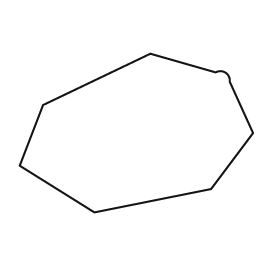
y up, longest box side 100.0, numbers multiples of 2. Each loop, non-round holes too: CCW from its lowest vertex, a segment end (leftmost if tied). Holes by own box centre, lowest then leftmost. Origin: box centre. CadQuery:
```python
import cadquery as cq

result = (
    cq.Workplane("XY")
    .moveTo(-18.0, -34.0)
    .lineTo(32.0, -24.0)
    .lineTo(50.0, 0.0)
    .lineTo(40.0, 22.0)
    .threePointArc((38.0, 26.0), (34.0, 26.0))
    .lineTo(6.0, 34.0)
    .lineTo(-40.0, 12.0)
    .lineTo(-50.0, -14.0)
    .close()
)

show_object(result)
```